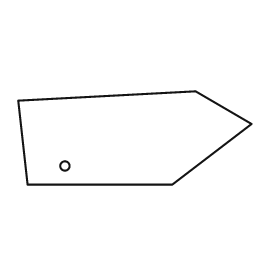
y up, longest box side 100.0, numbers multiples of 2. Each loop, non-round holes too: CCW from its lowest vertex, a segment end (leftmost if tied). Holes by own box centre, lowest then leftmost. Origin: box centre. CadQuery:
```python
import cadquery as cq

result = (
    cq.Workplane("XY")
    .moveTo(-46.0, -20.0)
    .lineTo(16.0, -20.0)
    .lineTo(50.0, 6.0)
    .lineTo(26.0, 20.0)
    .lineTo(-50.0, 16.0)
    .close()
    .moveTo(-30.0, -12.0)
    .circle(2.0)
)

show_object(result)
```